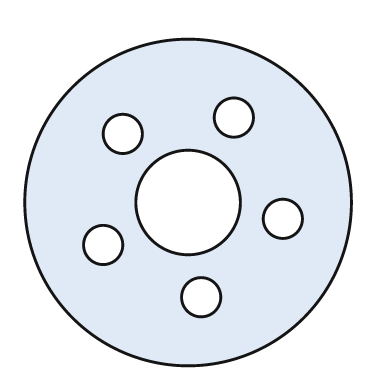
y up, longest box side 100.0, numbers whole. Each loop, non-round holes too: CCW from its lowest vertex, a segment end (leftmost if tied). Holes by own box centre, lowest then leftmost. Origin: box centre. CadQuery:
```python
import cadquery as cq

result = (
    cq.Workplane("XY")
    .moveTo(0.0, 0.0)
    .circle(50.0)
    .moveTo(4.0, -29.0)
    .circle(6.0)
    .moveTo(-26.0, -13.0)
    .circle(6.0)
    .moveTo(29.0, -5.0)
    .circle(6.0)
    .moveTo(0.0, 0.0)
    .circle(16.0)
    .moveTo(-20.0, 21.0)
    .circle(6.0)
    .moveTo(14.0, 26.0)
    .circle(6.0)
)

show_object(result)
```